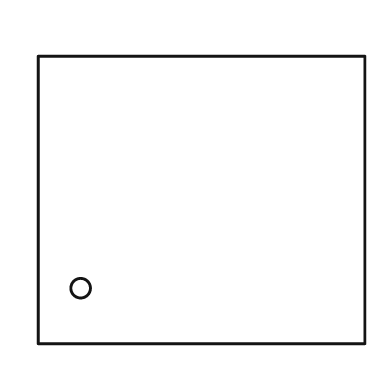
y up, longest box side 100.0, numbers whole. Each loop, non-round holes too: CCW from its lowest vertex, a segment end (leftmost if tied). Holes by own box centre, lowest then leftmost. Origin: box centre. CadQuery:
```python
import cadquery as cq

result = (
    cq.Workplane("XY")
    .moveTo(-50.0, -44.0)
    .lineTo(50.0, -44.0)
    .lineTo(50.0, 44.0)
    .lineTo(-50.0, 44.0)
    .close()
    .moveTo(-37.0, -27.0)
    .circle(3.0)
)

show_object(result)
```